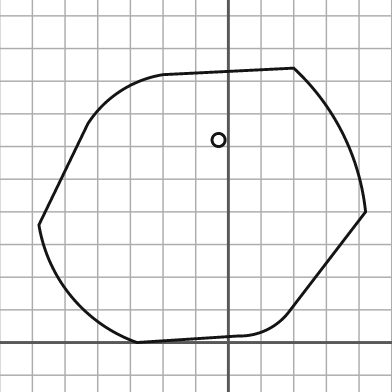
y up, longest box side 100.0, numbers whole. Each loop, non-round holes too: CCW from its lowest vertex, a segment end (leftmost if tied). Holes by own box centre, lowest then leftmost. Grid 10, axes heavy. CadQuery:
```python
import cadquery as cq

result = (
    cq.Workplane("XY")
    .moveTo(-28.0, 0.0)
    .lineTo(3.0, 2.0)
    .threePointArc((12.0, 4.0), (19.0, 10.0))
    .lineTo(42.0, 40.0)
    .threePointArc((35.0, 64.0), (20.0, 84.0))
    .lineTo(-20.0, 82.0)
    .threePointArc((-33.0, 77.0), (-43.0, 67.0))
    .lineTo(-58.0, 36.0)
    .threePointArc((-48.0, 14.0), (-28.0, 0.0))
    .close()
    .moveTo(-3.0, 62.0)
    .circle(2.0)
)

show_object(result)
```